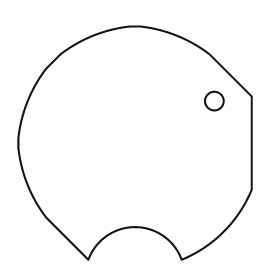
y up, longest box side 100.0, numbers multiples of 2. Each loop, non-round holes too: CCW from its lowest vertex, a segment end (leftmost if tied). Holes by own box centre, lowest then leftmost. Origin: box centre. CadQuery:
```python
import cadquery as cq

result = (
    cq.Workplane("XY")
    .moveTo(-20.0, -50.0)
    .threePointArc((0.0, -36.0), (20.0, -50.0))
    .threePointArc((38.0, -38.0), (50.0, -20.0))
    .lineTo(50.0, 20.0)
    .lineTo(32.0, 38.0)
    .threePointArc((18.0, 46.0), (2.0, 50.0))
    .lineTo(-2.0, 50.0)
    .threePointArc((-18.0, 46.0), (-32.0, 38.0))
    .lineTo(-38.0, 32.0)
    .threePointArc((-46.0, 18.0), (-50.0, 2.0))
    .lineTo(-50.0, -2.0)
    .threePointArc((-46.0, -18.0), (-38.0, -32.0))
    .close()
    .moveTo(34.0, 18.0)
    .circle(4.0)
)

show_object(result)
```